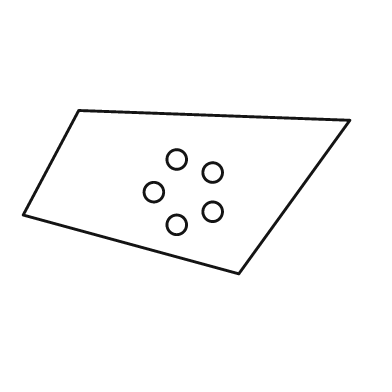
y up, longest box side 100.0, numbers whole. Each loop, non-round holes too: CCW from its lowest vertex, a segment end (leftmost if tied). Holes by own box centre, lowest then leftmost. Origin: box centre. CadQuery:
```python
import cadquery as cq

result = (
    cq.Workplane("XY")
    .moveTo(16.0, -25.0)
    .lineTo(50.0, 22.0)
    .lineTo(-33.0, 25.0)
    .lineTo(-50.0, -7.0)
    .close()
    .moveTo(-3.0, -10.0)
    .circle(3.0)
    .moveTo(8.0, -6.0)
    .circle(3.0)
    .moveTo(-10.0, 0.0)
    .circle(3.0)
    .moveTo(8.0, 6.0)
    .circle(3.0)
    .moveTo(-3.0, 10.0)
    .circle(3.0)
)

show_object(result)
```